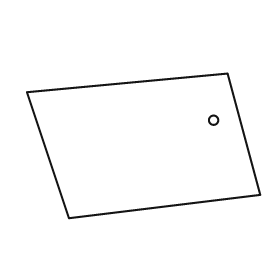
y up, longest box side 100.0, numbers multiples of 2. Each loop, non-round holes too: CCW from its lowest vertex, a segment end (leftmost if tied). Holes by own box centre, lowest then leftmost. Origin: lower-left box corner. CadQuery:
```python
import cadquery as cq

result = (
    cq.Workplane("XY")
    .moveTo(18.0, 0.0)
    .lineTo(100.0, 10.0)
    .lineTo(86.0, 62.0)
    .lineTo(0.0, 54.0)
    .close()
    .moveTo(80.0, 42.0)
    .circle(2.0)
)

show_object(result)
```